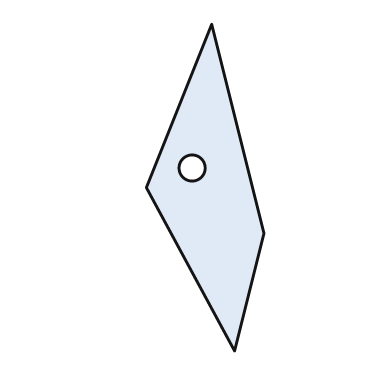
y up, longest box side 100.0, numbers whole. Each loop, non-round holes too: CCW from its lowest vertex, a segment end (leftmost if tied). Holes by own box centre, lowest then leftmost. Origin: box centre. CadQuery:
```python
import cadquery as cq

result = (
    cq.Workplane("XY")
    .moveTo(9.0, -50.0)
    .lineTo(18.0, -14.0)
    .lineTo(2.0, 50.0)
    .lineTo(-18.0, 0.0)
    .close()
    .moveTo(-4.0, 6.0)
    .circle(4.0)
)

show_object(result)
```